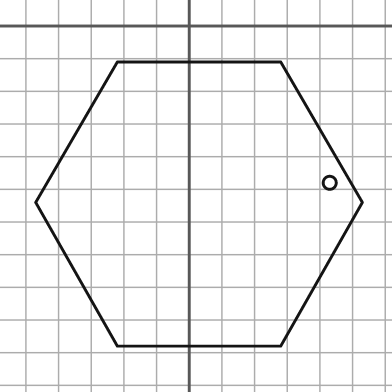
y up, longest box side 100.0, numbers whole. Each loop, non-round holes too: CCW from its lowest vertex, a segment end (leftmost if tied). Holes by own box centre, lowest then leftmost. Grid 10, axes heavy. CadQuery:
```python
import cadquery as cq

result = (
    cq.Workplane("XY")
    .moveTo(-22.0, -98.0)
    .lineTo(28.0, -98.0)
    .lineTo(53.0, -54.0)
    .lineTo(28.0, -11.0)
    .lineTo(-22.0, -11.0)
    .lineTo(-47.0, -54.0)
    .close()
    .moveTo(43.0, -48.0)
    .circle(2.0)
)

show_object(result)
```